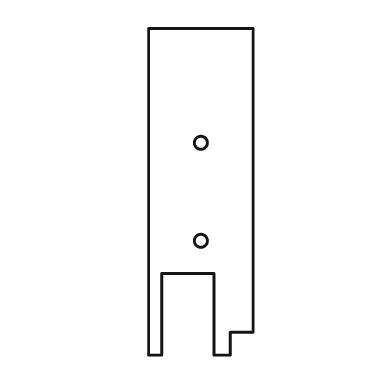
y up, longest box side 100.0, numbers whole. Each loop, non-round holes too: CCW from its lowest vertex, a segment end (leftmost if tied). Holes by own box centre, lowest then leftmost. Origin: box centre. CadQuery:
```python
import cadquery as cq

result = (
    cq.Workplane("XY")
    .moveTo(-16.0, -50.0)
    .lineTo(-12.0, -50.0)
    .lineTo(-12.0, -25.0)
    .lineTo(4.0, -25.0)
    .lineTo(4.0, -50.0)
    .lineTo(9.0, -50.0)
    .lineTo(9.0, -43.0)
    .lineTo(16.0, -43.0)
    .lineTo(16.0, 50.0)
    .lineTo(-16.0, 50.0)
    .close()
    .moveTo(0.0, -15.0)
    .circle(2.0)
    .moveTo(0.0, 15.0)
    .circle(2.0)
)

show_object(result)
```